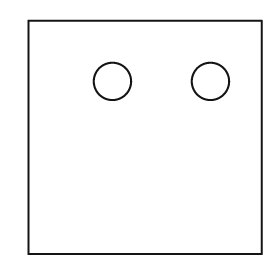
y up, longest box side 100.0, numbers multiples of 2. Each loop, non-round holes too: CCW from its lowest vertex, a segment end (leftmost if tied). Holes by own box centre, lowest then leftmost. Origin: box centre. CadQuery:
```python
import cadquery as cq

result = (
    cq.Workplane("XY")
    .moveTo(-50.0, -50.0)
    .lineTo(50.0, -50.0)
    .lineTo(50.0, 50.0)
    .lineTo(-50.0, 50.0)
    .close()
    .moveTo(-14.0, 24.0)
    .circle(8.0)
    .moveTo(28.0, 24.0)
    .circle(8.0)
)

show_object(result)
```